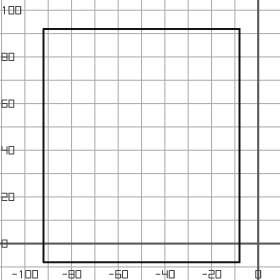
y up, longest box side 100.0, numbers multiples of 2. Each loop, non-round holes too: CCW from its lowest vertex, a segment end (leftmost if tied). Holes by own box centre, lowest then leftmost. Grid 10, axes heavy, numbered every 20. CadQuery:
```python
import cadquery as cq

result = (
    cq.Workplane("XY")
    .moveTo(-92.0, -8.0)
    .lineTo(-8.0, -8.0)
    .lineTo(-8.0, 92.0)
    .lineTo(-92.0, 92.0)
    .close()
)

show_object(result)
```